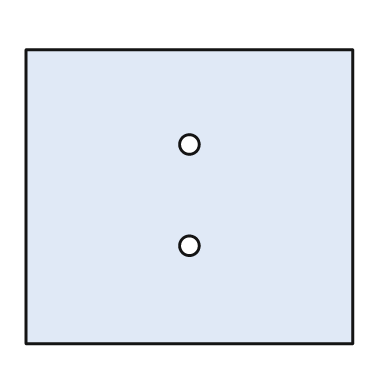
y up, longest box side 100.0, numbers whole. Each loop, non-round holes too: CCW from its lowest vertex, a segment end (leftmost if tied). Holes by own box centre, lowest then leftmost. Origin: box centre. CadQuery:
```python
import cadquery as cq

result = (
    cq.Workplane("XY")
    .moveTo(-50.0, -45.0)
    .lineTo(50.0, -45.0)
    .lineTo(50.0, 45.0)
    .lineTo(-50.0, 45.0)
    .close()
    .moveTo(0.0, -15.0)
    .circle(3.0)
    .moveTo(0.0, 16.0)
    .circle(3.0)
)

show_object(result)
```